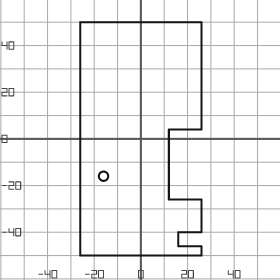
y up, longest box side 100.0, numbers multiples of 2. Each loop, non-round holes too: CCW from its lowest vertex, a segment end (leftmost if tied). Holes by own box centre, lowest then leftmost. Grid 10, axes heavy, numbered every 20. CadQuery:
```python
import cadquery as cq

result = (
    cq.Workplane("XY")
    .moveTo(-26.0, -50.0)
    .lineTo(26.0, -50.0)
    .lineTo(26.0, -46.0)
    .lineTo(16.0, -46.0)
    .lineTo(16.0, -40.0)
    .lineTo(26.0, -40.0)
    .lineTo(26.0, -26.0)
    .lineTo(12.0, -26.0)
    .lineTo(12.0, 4.0)
    .lineTo(26.0, 4.0)
    .lineTo(26.0, 50.0)
    .lineTo(-26.0, 50.0)
    .close()
    .moveTo(-16.0, -16.0)
    .circle(2.0)
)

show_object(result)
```